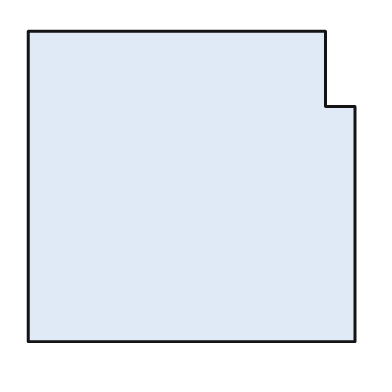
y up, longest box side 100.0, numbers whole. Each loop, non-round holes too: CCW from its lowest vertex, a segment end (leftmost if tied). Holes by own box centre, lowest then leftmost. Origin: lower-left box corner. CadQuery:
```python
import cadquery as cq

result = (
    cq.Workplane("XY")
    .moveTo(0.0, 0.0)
    .lineTo(100.0, 0.0)
    .lineTo(100.0, 72.0)
    .lineTo(91.0, 72.0)
    .lineTo(91.0, 95.0)
    .lineTo(0.0, 95.0)
    .close()
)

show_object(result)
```